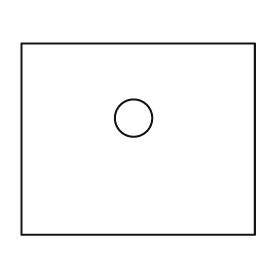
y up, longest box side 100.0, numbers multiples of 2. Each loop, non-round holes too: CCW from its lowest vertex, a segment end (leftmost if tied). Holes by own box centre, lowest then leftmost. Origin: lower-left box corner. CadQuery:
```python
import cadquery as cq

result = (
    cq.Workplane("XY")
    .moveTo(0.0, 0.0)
    .lineTo(100.0, 0.0)
    .lineTo(100.0, 82.0)
    .lineTo(0.0, 82.0)
    .close()
    .moveTo(48.0, 50.0)
    .circle(8.0)
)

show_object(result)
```